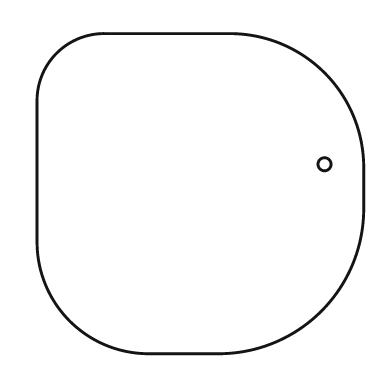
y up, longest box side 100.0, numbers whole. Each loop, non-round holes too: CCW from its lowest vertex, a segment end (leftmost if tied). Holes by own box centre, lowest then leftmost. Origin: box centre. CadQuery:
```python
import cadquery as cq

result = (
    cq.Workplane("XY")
    .moveTo(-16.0, -49.0)
    .lineTo(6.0, -49.0)
    .threePointArc((37.0, -36.0), (50.0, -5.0))
    .lineTo(50.0, 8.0)
    .threePointArc((38.0, 37.0), (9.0, 49.0))
    .lineTo(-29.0, 49.0)
    .threePointArc((-44.0, 43.0), (-50.0, 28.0))
    .lineTo(-50.0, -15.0)
    .threePointArc((-40.0, -39.0), (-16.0, -49.0))
    .close()
    .moveTo(38.0, 9.0)
    .circle(2.0)
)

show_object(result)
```